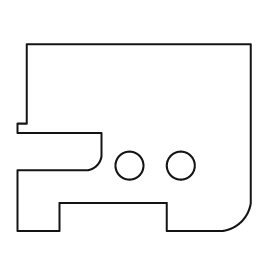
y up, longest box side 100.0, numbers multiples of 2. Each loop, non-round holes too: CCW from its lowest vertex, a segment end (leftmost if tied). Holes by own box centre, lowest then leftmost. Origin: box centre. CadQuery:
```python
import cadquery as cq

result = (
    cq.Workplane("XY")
    .moveTo(-50.0, -40.0)
    .lineTo(-32.0, -40.0)
    .lineTo(-32.0, -28.0)
    .lineTo(14.0, -28.0)
    .lineTo(14.0, -40.0)
    .lineTo(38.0, -40.0)
    .threePointArc((46.0, -36.0), (50.0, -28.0))
    .lineTo(50.0, 40.0)
    .lineTo(-46.0, 40.0)
    .lineTo(-46.0, 6.0)
    .lineTo(-50.0, 6.0)
    .lineTo(-50.0, 2.0)
    .lineTo(-14.0, 2.0)
    .lineTo(-14.0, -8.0)
    .threePointArc((-16.0, -12.0), (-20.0, -14.0))
    .lineTo(-50.0, -14.0)
    .close()
    .moveTo(-2.0, -12.0)
    .circle(6.0)
    .moveTo(20.0, -12.0)
    .circle(6.0)
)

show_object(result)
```